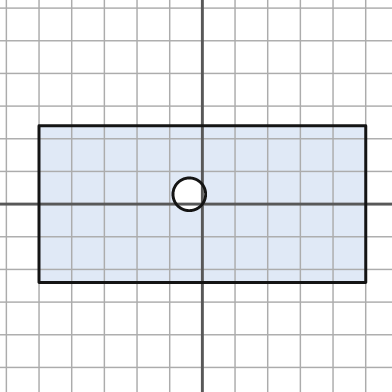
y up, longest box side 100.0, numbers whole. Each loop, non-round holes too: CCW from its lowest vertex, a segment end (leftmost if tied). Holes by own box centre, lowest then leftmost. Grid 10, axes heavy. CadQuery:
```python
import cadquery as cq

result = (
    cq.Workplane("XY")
    .moveTo(-50.0, -24.0)
    .lineTo(50.0, -24.0)
    .lineTo(50.0, 24.0)
    .lineTo(-50.0, 24.0)
    .close()
    .moveTo(-4.0, 3.0)
    .circle(5.0)
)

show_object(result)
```